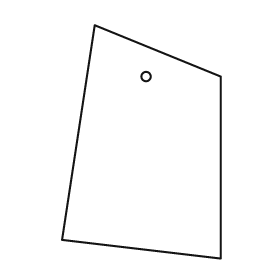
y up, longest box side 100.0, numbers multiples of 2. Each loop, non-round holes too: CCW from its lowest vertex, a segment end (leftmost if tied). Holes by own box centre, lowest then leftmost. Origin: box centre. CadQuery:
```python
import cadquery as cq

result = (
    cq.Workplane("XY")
    .moveTo(34.0, -50.0)
    .lineTo(34.0, 28.0)
    .lineTo(-20.0, 50.0)
    .lineTo(-34.0, -42.0)
    .close()
    .moveTo(2.0, 28.0)
    .circle(2.0)
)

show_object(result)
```